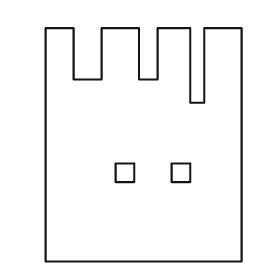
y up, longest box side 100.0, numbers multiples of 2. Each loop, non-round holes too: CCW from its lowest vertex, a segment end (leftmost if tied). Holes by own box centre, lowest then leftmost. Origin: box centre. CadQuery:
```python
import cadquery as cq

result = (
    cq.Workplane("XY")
    .moveTo(-42.0, -50.0)
    .lineTo(42.0, -50.0)
    .lineTo(42.0, 50.0)
    .lineTo(26.0, 50.0)
    .lineTo(26.0, 18.0)
    .lineTo(20.0, 18.0)
    .lineTo(20.0, 50.0)
    .lineTo(6.0, 50.0)
    .lineTo(6.0, 28.0)
    .lineTo(-2.0, 28.0)
    .lineTo(-2.0, 50.0)
    .lineTo(-18.0, 50.0)
    .lineTo(-18.0, 28.0)
    .lineTo(-30.0, 28.0)
    .lineTo(-30.0, 50.0)
    .lineTo(-42.0, 50.0)
    .close()
    .moveTo(-12.0, -16.0)
    .lineTo(-4.0, -16.0)
    .lineTo(-4.0, -8.0)
    .lineTo(-12.0, -8.0)
    .close()
    .moveTo(12.0, -16.0)
    .lineTo(20.0, -16.0)
    .lineTo(20.0, -8.0)
    .lineTo(12.0, -8.0)
    .close()
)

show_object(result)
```